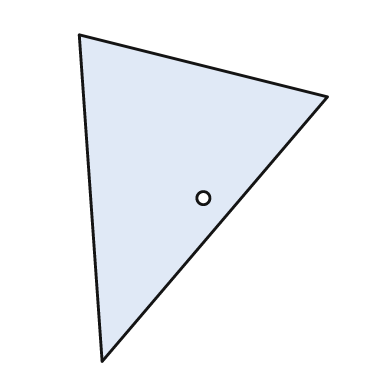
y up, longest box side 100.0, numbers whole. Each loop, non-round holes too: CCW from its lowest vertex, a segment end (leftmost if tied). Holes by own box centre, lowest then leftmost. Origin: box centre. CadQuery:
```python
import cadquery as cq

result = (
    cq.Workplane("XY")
    .moveTo(-31.0, -50.0)
    .lineTo(38.0, 31.0)
    .lineTo(-38.0, 50.0)
    .close()
    .moveTo(0.0, 0.0)
    .circle(2.0)
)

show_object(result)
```